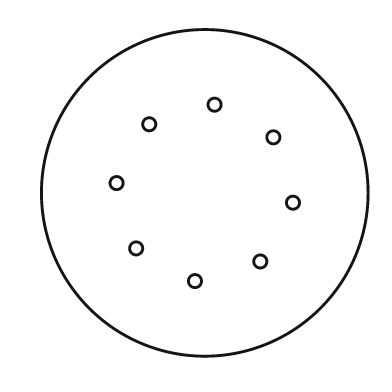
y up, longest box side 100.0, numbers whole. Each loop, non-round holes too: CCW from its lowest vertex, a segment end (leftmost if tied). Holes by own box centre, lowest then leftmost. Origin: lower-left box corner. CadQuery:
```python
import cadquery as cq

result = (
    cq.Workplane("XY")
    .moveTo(50.0, 50.0)
    .circle(50.0)
    .moveTo(47.0, 23.0)
    .circle(2.0)
    .moveTo(67.0, 29.0)
    .circle(2.0)
    .moveTo(29.0, 33.0)
    .circle(2.0)
    .moveTo(77.0, 47.0)
    .circle(2.0)
    .moveTo(23.0, 53.0)
    .circle(2.0)
    .moveTo(71.0, 67.0)
    .circle(2.0)
    .moveTo(33.0, 71.0)
    .circle(2.0)
    .moveTo(53.0, 77.0)
    .circle(2.0)
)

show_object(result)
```